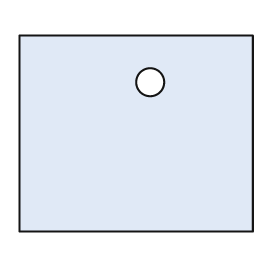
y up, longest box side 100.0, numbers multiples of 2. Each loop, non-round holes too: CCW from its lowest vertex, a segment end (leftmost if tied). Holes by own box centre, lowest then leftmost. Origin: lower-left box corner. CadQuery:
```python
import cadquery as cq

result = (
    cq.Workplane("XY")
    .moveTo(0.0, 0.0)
    .lineTo(100.0, 0.0)
    .lineTo(100.0, 84.0)
    .lineTo(0.0, 84.0)
    .close()
    .moveTo(56.0, 64.0)
    .circle(6.0)
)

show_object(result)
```